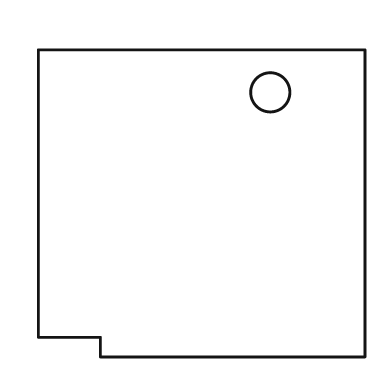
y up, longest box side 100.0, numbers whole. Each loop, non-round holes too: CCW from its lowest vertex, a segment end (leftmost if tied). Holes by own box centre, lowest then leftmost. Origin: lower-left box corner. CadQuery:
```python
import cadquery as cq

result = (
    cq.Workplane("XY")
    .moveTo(19.0, 0.0)
    .lineTo(100.0, 0.0)
    .lineTo(100.0, 94.0)
    .lineTo(0.0, 94.0)
    .lineTo(0.0, 6.0)
    .lineTo(19.0, 6.0)
    .close()
    .moveTo(71.0, 81.0)
    .circle(6.0)
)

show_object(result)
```